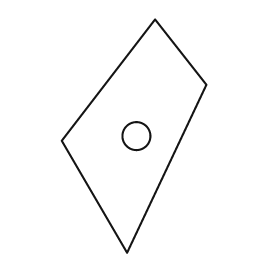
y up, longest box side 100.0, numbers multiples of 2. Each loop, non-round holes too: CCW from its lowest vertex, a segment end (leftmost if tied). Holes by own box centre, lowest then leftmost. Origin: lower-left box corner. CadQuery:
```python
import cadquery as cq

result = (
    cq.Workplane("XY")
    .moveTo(28.0, 0.0)
    .lineTo(62.0, 72.0)
    .lineTo(40.0, 100.0)
    .lineTo(0.0, 48.0)
    .close()
    .moveTo(32.0, 50.0)
    .circle(6.0)
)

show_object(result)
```